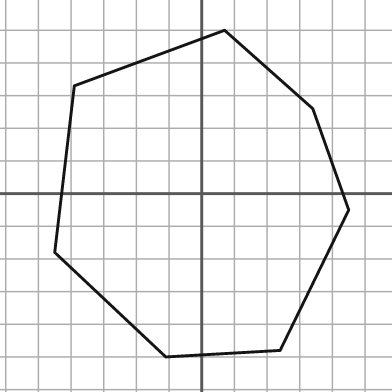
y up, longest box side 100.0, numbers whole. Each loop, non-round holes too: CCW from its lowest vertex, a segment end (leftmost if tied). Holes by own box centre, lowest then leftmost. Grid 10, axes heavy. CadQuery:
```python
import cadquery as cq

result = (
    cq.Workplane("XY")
    .moveTo(-11.0, -50.0)
    .lineTo(24.0, -48.0)
    .lineTo(45.0, -5.0)
    .lineTo(34.0, 26.0)
    .lineTo(7.0, 50.0)
    .lineTo(-39.0, 33.0)
    .lineTo(-45.0, -18.0)
    .close()
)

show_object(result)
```